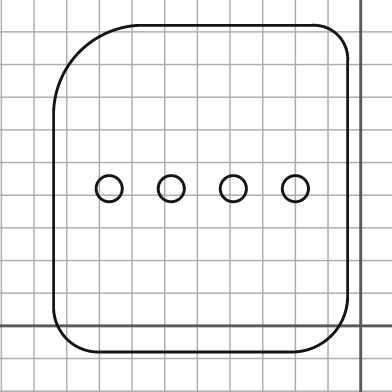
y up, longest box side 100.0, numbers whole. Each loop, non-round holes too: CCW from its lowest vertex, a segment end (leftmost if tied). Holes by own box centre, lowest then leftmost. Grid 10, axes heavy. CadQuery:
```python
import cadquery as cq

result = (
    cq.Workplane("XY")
    .moveTo(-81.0, -8.0)
    .lineTo(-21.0, -8.0)
    .threePointArc((-9.0, -3.0), (-4.0, 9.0))
    .lineTo(-4.0, 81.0)
    .threePointArc((-7.0, 89.0), (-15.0, 92.0))
    .lineTo(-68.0, 92.0)
    .threePointArc((-86.0, 84.0), (-94.0, 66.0))
    .lineTo(-94.0, 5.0)
    .threePointArc((-90.0, -4.0), (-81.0, -8.0))
    .close()
    .moveTo(-77.0, 42.0)
    .circle(4.0)
    .moveTo(-58.0, 42.0)
    .circle(4.0)
    .moveTo(-39.0, 42.0)
    .circle(4.0)
    .moveTo(-20.0, 42.0)
    .circle(4.0)
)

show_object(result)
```